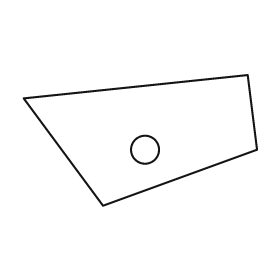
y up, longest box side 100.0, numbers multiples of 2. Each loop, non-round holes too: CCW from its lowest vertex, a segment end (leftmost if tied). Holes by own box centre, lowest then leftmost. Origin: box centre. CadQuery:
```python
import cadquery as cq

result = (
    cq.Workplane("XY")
    .moveTo(-16.0, -28.0)
    .lineTo(50.0, -4.0)
    .lineTo(46.0, 28.0)
    .lineTo(-50.0, 18.0)
    .close()
    .moveTo(2.0, -4.0)
    .circle(6.0)
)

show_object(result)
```